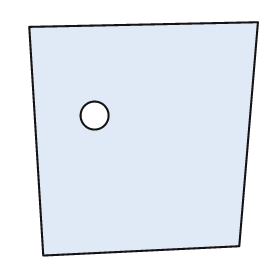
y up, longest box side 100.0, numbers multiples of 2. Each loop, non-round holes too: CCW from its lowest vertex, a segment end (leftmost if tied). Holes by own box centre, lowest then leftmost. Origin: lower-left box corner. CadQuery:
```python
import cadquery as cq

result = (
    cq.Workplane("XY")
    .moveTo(6.0, 0.0)
    .lineTo(90.0, 4.0)
    .lineTo(98.0, 100.0)
    .lineTo(0.0, 98.0)
    .close()
    .moveTo(28.0, 60.0)
    .circle(6.0)
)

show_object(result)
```